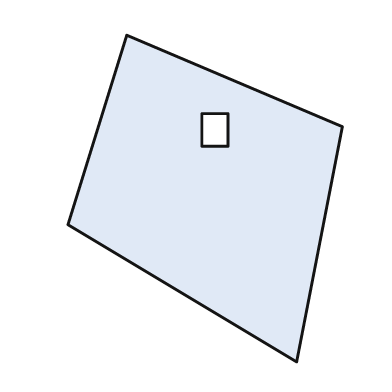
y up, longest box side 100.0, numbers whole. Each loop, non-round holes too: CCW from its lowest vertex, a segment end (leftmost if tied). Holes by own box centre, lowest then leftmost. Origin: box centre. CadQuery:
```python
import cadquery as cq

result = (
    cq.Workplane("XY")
    .moveTo(28.0, -50.0)
    .lineTo(42.0, 22.0)
    .lineTo(-24.0, 50.0)
    .lineTo(-42.0, -8.0)
    .close()
    .moveTo(-1.0, 16.0)
    .lineTo(7.0, 16.0)
    .lineTo(7.0, 26.0)
    .lineTo(-1.0, 26.0)
    .close()
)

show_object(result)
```